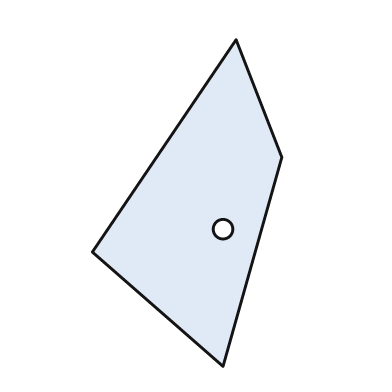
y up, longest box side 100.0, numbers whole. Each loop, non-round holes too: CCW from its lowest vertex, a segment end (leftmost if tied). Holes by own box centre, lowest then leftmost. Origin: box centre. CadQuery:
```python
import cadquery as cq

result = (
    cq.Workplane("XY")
    .moveTo(11.0, -50.0)
    .lineTo(29.0, 14.0)
    .lineTo(15.0, 50.0)
    .lineTo(-29.0, -15.0)
    .close()
    .moveTo(11.0, -8.0)
    .circle(3.0)
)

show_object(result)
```